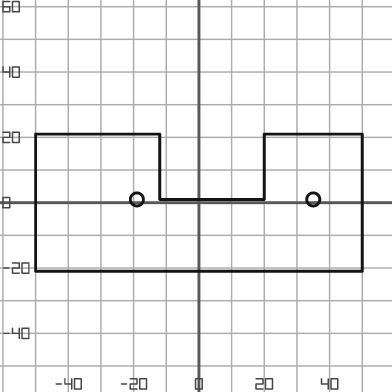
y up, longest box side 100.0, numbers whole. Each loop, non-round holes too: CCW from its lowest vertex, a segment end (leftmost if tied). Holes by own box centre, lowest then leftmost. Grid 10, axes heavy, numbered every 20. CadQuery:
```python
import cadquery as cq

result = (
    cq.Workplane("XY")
    .moveTo(-50.0, -21.0)
    .lineTo(50.0, -21.0)
    .lineTo(50.0, 21.0)
    .lineTo(20.0, 21.0)
    .lineTo(20.0, 1.0)
    .lineTo(-12.0, 1.0)
    .lineTo(-12.0, 21.0)
    .lineTo(-50.0, 21.0)
    .close()
    .moveTo(-19.0, 1.0)
    .circle(2.0)
    .moveTo(35.0, 1.0)
    .circle(2.0)
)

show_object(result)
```